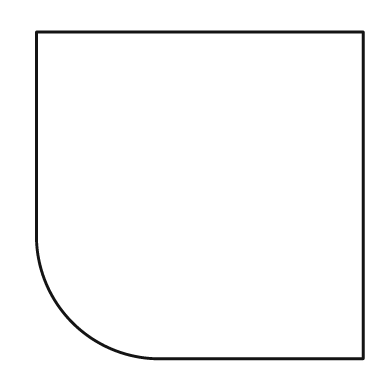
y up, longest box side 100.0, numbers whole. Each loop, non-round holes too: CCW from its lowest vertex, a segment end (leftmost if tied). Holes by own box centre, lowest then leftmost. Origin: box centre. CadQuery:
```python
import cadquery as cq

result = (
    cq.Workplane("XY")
    .moveTo(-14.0, -50.0)
    .lineTo(50.0, -50.0)
    .lineTo(50.0, 50.0)
    .lineTo(-50.0, 50.0)
    .lineTo(-50.0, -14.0)
    .threePointArc((-39.0, -39.0), (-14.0, -50.0))
    .close()
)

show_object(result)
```